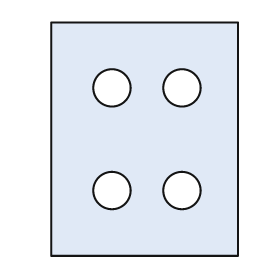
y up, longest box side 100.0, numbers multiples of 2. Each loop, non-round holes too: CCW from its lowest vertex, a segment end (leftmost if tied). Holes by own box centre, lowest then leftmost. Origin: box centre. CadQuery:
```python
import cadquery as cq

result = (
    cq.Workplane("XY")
    .moveTo(-40.0, -50.0)
    .lineTo(40.0, -50.0)
    .lineTo(40.0, 50.0)
    .lineTo(-40.0, 50.0)
    .close()
    .moveTo(-14.0, -22.0)
    .circle(8.0)
    .moveTo(16.0, -22.0)
    .circle(8.0)
    .moveTo(-14.0, 22.0)
    .circle(8.0)
    .moveTo(16.0, 22.0)
    .circle(8.0)
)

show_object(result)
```